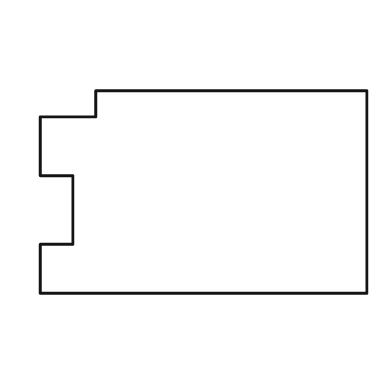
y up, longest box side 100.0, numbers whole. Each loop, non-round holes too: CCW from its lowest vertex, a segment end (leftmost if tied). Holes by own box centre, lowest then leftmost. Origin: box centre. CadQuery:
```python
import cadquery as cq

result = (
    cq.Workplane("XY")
    .moveTo(-50.0, -31.0)
    .lineTo(50.0, -31.0)
    .lineTo(50.0, 31.0)
    .lineTo(-33.0, 31.0)
    .lineTo(-33.0, 23.0)
    .lineTo(-50.0, 23.0)
    .lineTo(-50.0, 5.0)
    .lineTo(-40.0, 5.0)
    .lineTo(-40.0, -16.0)
    .lineTo(-50.0, -16.0)
    .close()
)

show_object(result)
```